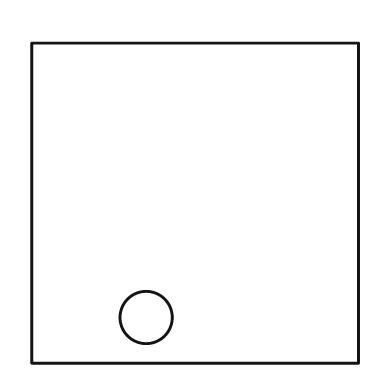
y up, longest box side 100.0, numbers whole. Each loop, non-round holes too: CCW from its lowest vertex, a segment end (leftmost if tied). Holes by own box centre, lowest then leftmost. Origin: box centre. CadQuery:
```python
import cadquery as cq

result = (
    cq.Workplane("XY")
    .moveTo(-50.0, -49.0)
    .lineTo(50.0, -49.0)
    .lineTo(50.0, 49.0)
    .lineTo(-50.0, 49.0)
    .close()
    .moveTo(-15.0, -35.0)
    .circle(8.0)
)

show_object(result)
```